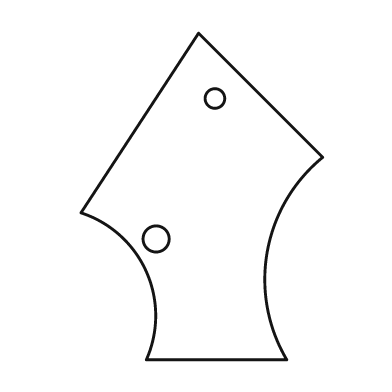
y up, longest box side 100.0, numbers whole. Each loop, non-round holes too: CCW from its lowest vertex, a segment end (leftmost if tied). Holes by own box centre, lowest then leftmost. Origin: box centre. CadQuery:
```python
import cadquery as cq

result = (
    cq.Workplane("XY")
    .moveTo(-17.0, -50.0)
    .lineTo(26.0, -50.0)
    .threePointArc((20.0, -17.0), (37.0, 12.0))
    .lineTo(-1.0, 50.0)
    .lineTo(-37.0, -5.0)
    .threePointArc((-17.0, -23.0), (-17.0, -50.0))
    .close()
    .moveTo(-14.0, -13.0)
    .circle(4.0)
    .moveTo(4.0, 30.0)
    .circle(3.0)
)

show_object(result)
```